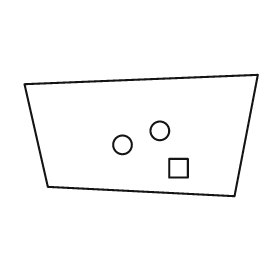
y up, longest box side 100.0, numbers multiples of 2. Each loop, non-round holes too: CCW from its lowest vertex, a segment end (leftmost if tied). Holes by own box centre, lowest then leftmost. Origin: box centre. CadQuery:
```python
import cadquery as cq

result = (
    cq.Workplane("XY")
    .moveTo(40.0, -26.0)
    .lineTo(50.0, 26.0)
    .lineTo(-50.0, 22.0)
    .lineTo(-40.0, -22.0)
    .close()
    .moveTo(12.0, -18.0)
    .lineTo(20.0, -18.0)
    .lineTo(20.0, -10.0)
    .lineTo(12.0, -10.0)
    .close()
    .moveTo(-8.0, -4.0)
    .circle(4.0)
    .moveTo(8.0, 2.0)
    .circle(4.0)
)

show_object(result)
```